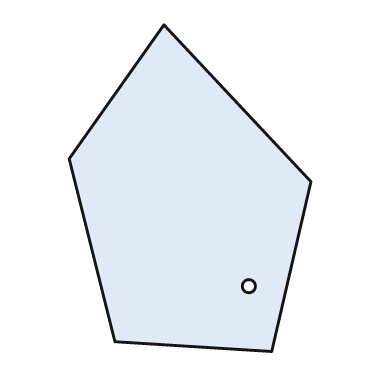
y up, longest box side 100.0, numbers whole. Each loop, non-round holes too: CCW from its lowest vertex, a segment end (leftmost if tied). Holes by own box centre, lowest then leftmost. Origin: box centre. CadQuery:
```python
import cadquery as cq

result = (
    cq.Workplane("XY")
    .moveTo(25.0, -50.0)
    .lineTo(37.0, 2.0)
    .lineTo(-8.0, 50.0)
    .lineTo(-37.0, 9.0)
    .lineTo(-23.0, -47.0)
    .close()
    .moveTo(18.0, -30.0)
    .circle(2.0)
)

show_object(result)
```